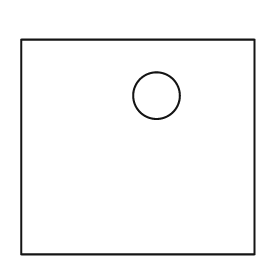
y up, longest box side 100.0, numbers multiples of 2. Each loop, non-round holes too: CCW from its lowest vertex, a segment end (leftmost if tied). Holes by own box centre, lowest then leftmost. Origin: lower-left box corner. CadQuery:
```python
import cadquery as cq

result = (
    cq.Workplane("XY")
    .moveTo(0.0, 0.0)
    .lineTo(100.0, 0.0)
    .lineTo(100.0, 92.0)
    .lineTo(0.0, 92.0)
    .close()
    .moveTo(58.0, 68.0)
    .circle(10.0)
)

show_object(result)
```